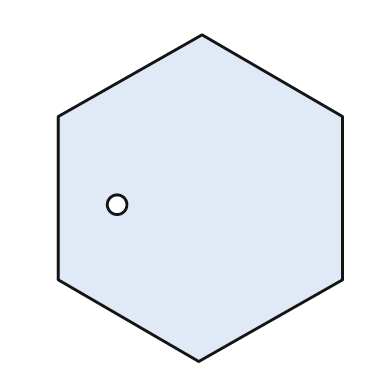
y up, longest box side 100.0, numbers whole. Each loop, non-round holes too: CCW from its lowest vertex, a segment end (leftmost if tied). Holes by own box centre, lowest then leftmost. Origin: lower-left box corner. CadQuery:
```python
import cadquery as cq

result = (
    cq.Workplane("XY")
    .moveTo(43.0, 0.0)
    .lineTo(87.0, 25.0)
    .lineTo(87.0, 75.0)
    .lineTo(44.0, 100.0)
    .lineTo(0.0, 75.0)
    .lineTo(0.0, 25.0)
    .close()
    .moveTo(18.0, 48.0)
    .circle(3.0)
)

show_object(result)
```